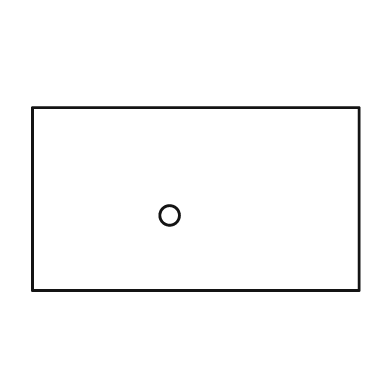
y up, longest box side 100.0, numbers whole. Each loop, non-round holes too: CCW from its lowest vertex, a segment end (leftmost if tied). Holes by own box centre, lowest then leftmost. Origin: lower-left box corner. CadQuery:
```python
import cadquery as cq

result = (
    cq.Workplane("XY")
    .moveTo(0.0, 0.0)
    .lineTo(100.0, 0.0)
    .lineTo(100.0, 56.0)
    .lineTo(0.0, 56.0)
    .close()
    .moveTo(42.0, 23.0)
    .circle(3.0)
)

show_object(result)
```